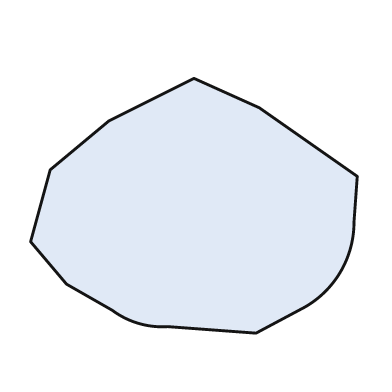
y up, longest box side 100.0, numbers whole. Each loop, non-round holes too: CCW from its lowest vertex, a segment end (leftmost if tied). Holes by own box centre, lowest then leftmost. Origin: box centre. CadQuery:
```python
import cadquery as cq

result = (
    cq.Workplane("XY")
    .moveTo(19.0, -39.0)
    .lineTo(34.0, -31.0)
    .threePointArc((45.0, -20.0), (49.0, -5.0))
    .lineTo(50.0, 9.0)
    .lineTo(20.0, 30.0)
    .lineTo(0.0, 39.0)
    .lineTo(-26.0, 26.0)
    .lineTo(-44.0, 11.0)
    .lineTo(-50.0, -11.0)
    .lineTo(-39.0, -24.0)
    .lineTo(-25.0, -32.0)
    .threePointArc((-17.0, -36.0), (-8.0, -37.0))
    .close()
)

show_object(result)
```